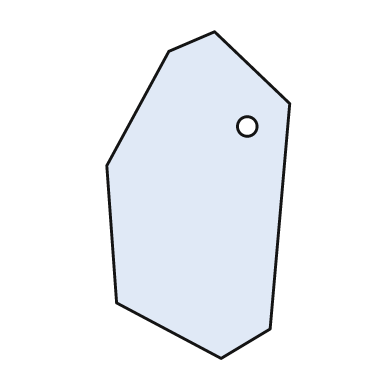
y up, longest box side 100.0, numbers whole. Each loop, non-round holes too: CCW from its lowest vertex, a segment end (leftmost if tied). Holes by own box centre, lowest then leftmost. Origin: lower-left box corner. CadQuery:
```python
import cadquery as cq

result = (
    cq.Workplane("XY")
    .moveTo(35.0, 0.0)
    .lineTo(50.0, 9.0)
    .lineTo(56.0, 78.0)
    .lineTo(33.0, 100.0)
    .lineTo(19.0, 94.0)
    .lineTo(0.0, 59.0)
    .lineTo(3.0, 17.0)
    .close()
    .moveTo(43.0, 71.0)
    .circle(3.0)
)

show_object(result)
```